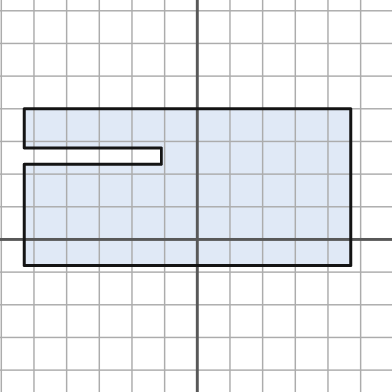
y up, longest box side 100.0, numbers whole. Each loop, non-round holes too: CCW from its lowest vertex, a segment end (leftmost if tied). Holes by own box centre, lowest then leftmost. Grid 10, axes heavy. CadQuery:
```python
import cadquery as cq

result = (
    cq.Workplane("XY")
    .moveTo(-53.0, -8.0)
    .lineTo(47.0, -8.0)
    .lineTo(47.0, 40.0)
    .lineTo(-53.0, 40.0)
    .lineTo(-53.0, 28.0)
    .lineTo(-11.0, 28.0)
    .lineTo(-11.0, 23.0)
    .lineTo(-53.0, 23.0)
    .close()
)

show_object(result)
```